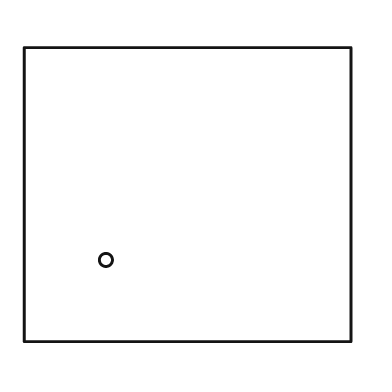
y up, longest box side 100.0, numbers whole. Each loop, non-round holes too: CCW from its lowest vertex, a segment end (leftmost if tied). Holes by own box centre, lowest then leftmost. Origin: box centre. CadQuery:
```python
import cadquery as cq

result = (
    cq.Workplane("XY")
    .moveTo(-50.0, -45.0)
    .lineTo(50.0, -45.0)
    .lineTo(50.0, 45.0)
    .lineTo(-50.0, 45.0)
    .close()
    .moveTo(-25.0, -20.0)
    .circle(2.0)
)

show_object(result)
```